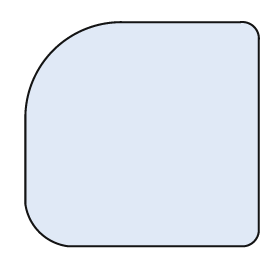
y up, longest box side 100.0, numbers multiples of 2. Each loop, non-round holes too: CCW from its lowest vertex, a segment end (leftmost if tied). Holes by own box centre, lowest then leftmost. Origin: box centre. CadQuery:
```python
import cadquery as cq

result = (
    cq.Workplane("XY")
    .moveTo(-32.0, -48.0)
    .lineTo(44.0, -48.0)
    .threePointArc((48.0, -46.0), (50.0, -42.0))
    .lineTo(50.0, 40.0)
    .threePointArc((48.0, 46.0), (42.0, 48.0))
    .lineTo(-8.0, 48.0)
    .threePointArc((-38.0, 36.0), (-50.0, 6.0))
    .lineTo(-50.0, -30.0)
    .threePointArc((-44.0, -42.0), (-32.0, -48.0))
    .close()
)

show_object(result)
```